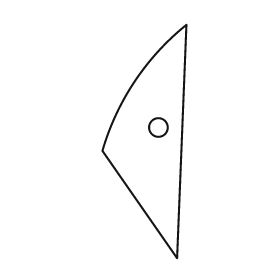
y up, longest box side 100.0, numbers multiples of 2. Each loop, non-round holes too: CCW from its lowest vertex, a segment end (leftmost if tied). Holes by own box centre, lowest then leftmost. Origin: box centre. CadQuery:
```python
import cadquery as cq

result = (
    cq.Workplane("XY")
    .moveTo(14.0, -50.0)
    .lineTo(18.0, 50.0)
    .threePointArc((-4.0, 26.0), (-18.0, -4.0))
    .close()
    .moveTo(6.0, 6.0)
    .circle(4.0)
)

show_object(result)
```